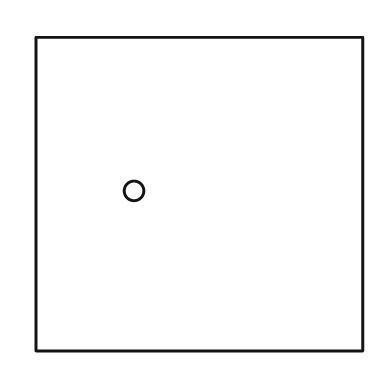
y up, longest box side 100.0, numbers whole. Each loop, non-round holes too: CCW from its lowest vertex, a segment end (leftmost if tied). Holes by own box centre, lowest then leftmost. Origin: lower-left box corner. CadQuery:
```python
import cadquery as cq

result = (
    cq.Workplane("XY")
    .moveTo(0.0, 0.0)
    .lineTo(100.0, 0.0)
    .lineTo(100.0, 96.0)
    .lineTo(0.0, 96.0)
    .close()
    .moveTo(30.0, 49.0)
    .circle(3.0)
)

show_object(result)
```